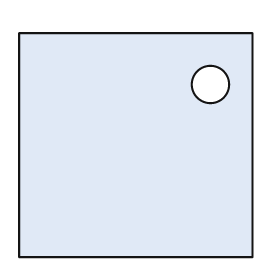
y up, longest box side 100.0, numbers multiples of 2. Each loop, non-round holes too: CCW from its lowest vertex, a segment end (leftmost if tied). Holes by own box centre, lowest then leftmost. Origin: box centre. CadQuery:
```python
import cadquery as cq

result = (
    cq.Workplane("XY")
    .moveTo(-50.0, -48.0)
    .lineTo(50.0, -48.0)
    .lineTo(50.0, 48.0)
    .lineTo(-50.0, 48.0)
    .close()
    .moveTo(32.0, 26.0)
    .circle(8.0)
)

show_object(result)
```